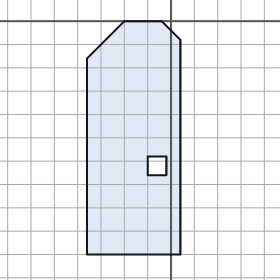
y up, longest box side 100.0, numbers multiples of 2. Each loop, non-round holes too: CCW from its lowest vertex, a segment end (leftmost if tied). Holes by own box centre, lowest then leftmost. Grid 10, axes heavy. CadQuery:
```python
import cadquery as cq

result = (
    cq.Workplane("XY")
    .moveTo(-36.0, -100.0)
    .lineTo(4.0, -100.0)
    .lineTo(4.0, -8.0)
    .lineTo(-4.0, 0.0)
    .lineTo(-20.0, 0.0)
    .lineTo(-36.0, -16.0)
    .close()
    .moveTo(-10.0, -66.0)
    .lineTo(-2.0, -66.0)
    .lineTo(-2.0, -58.0)
    .lineTo(-10.0, -58.0)
    .close()
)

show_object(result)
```